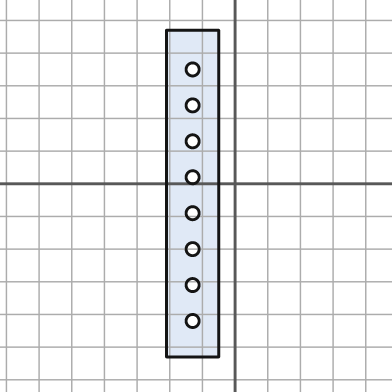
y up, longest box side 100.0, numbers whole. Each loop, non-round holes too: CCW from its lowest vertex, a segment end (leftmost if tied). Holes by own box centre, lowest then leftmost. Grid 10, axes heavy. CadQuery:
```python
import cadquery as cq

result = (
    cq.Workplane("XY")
    .moveTo(-21.0, -53.0)
    .lineTo(-5.0, -53.0)
    .lineTo(-5.0, 47.0)
    .lineTo(-21.0, 47.0)
    .close()
    .moveTo(-13.0, -42.0)
    .circle(2.0)
    .moveTo(-13.0, -31.0)
    .circle(2.0)
    .moveTo(-13.0, -20.0)
    .circle(2.0)
    .moveTo(-13.0, -9.0)
    .circle(2.0)
    .moveTo(-13.0, 2.0)
    .circle(2.0)
    .moveTo(-13.0, 13.0)
    .circle(2.0)
    .moveTo(-13.0, 24.0)
    .circle(2.0)
    .moveTo(-13.0, 35.0)
    .circle(2.0)
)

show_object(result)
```